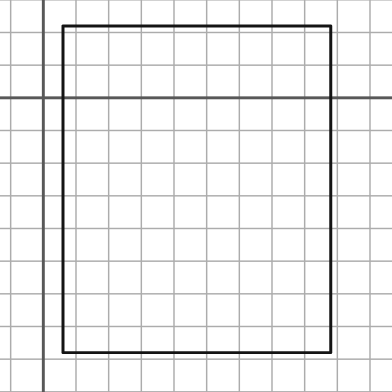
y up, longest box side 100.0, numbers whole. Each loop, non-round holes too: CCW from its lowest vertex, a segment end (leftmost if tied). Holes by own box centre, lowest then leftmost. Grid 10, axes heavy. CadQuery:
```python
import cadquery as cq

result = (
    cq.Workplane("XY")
    .moveTo(6.0, -78.0)
    .lineTo(88.0, -78.0)
    .lineTo(88.0, 22.0)
    .lineTo(6.0, 22.0)
    .close()
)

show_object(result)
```